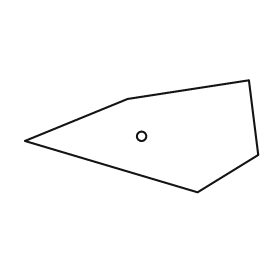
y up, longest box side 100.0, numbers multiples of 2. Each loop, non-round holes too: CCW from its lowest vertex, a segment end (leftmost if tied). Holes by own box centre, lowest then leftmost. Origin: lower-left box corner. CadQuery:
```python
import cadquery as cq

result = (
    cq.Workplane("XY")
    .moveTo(74.0, 0.0)
    .lineTo(100.0, 16.0)
    .lineTo(96.0, 48.0)
    .lineTo(44.0, 40.0)
    .lineTo(0.0, 22.0)
    .close()
    .moveTo(50.0, 24.0)
    .circle(2.0)
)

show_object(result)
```